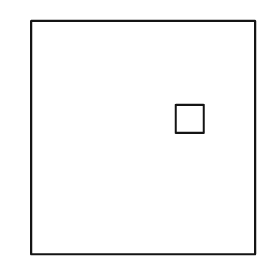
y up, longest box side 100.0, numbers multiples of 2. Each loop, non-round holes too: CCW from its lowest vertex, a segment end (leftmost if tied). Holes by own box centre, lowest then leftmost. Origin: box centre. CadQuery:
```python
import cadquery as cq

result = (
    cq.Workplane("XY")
    .moveTo(-48.0, -50.0)
    .lineTo(48.0, -50.0)
    .lineTo(48.0, 50.0)
    .lineTo(-48.0, 50.0)
    .close()
    .moveTo(14.0, 2.0)
    .lineTo(26.0, 2.0)
    .lineTo(26.0, 14.0)
    .lineTo(14.0, 14.0)
    .close()
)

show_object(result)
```